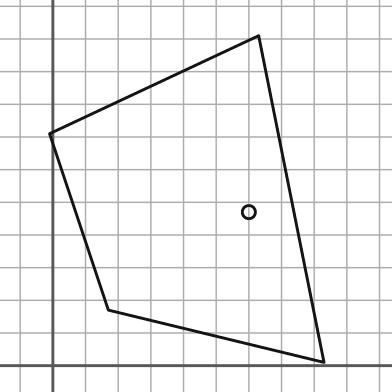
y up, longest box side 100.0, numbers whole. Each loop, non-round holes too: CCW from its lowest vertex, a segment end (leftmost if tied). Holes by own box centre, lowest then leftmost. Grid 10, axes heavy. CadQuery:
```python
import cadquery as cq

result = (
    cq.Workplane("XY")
    .moveTo(83.0, 1.0)
    .lineTo(63.0, 101.0)
    .lineTo(-1.0, 71.0)
    .lineTo(17.0, 17.0)
    .close()
    .moveTo(60.0, 47.0)
    .circle(2.0)
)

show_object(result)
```